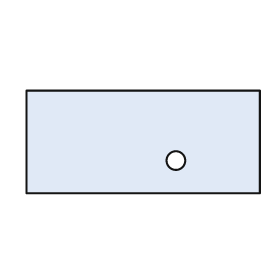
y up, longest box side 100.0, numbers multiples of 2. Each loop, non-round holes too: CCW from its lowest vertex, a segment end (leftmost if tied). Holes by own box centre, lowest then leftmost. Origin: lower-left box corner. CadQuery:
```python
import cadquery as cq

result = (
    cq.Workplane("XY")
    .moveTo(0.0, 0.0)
    .lineTo(100.0, 0.0)
    .lineTo(100.0, 44.0)
    .lineTo(0.0, 44.0)
    .close()
    .moveTo(64.0, 14.0)
    .circle(4.0)
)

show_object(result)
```